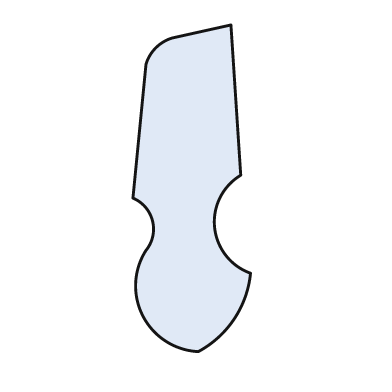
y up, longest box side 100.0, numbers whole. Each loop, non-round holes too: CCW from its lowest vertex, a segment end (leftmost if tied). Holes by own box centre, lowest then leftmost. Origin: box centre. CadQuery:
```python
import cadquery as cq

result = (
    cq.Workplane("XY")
    .moveTo(2.0, -50.0)
    .threePointArc((13.0, -40.0), (18.0, -26.0))
    .threePointArc((7.0, -12.0), (15.0, 4.0))
    .lineTo(12.0, 50.0)
    .lineTo(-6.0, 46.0)
    .threePointArc((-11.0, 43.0), (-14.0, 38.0))
    .lineTo(-18.0, -3.0)
    .threePointArc((-12.0, -10.0), (-14.0, -19.0))
    .threePointArc((-15.0, -39.0), (2.0, -50.0))
    .close()
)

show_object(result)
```